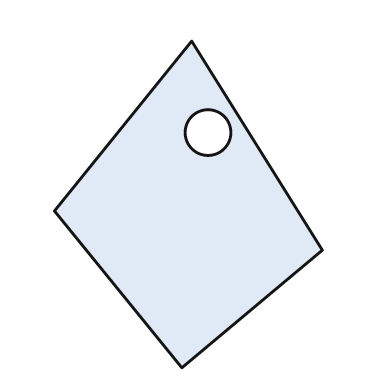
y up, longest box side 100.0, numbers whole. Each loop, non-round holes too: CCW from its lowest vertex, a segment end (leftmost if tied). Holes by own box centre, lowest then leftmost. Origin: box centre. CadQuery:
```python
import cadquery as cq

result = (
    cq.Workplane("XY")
    .moveTo(-2.0, -50.0)
    .lineTo(41.0, -14.0)
    .lineTo(1.0, 50.0)
    .lineTo(-41.0, -2.0)
    .close()
    .moveTo(6.0, 22.0)
    .circle(7.0)
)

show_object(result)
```